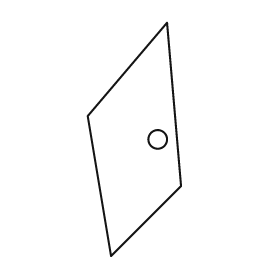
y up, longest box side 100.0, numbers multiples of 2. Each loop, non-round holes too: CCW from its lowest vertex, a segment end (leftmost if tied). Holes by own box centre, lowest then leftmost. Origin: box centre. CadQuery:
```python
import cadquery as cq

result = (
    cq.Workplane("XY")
    .moveTo(-10.0, -50.0)
    .lineTo(20.0, -20.0)
    .lineTo(14.0, 50.0)
    .lineTo(-20.0, 10.0)
    .close()
    .moveTo(10.0, 0.0)
    .circle(4.0)
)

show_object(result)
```